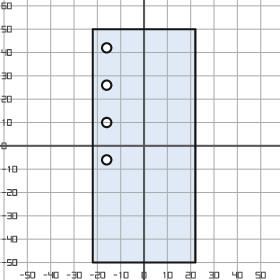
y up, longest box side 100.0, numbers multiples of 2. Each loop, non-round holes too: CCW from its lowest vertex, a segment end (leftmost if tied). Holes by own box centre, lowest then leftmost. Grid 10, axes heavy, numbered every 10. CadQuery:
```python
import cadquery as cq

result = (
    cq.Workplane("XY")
    .moveTo(-22.0, -50.0)
    .lineTo(22.0, -50.0)
    .lineTo(22.0, 50.0)
    .lineTo(-22.0, 50.0)
    .close()
    .moveTo(-16.0, -6.0)
    .circle(2.0)
    .moveTo(-16.0, 10.0)
    .circle(2.0)
    .moveTo(-16.0, 26.0)
    .circle(2.0)
    .moveTo(-16.0, 42.0)
    .circle(2.0)
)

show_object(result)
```